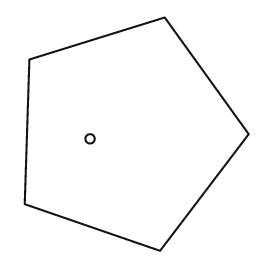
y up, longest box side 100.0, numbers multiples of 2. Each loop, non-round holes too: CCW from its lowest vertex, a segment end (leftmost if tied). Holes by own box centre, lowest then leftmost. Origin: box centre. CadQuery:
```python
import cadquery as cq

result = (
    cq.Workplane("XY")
    .moveTo(10.0, -50.0)
    .lineTo(48.0, 0.0)
    .lineTo(12.0, 50.0)
    .lineTo(-46.0, 32.0)
    .lineTo(-48.0, -30.0)
    .close()
    .moveTo(-20.0, -2.0)
    .circle(2.0)
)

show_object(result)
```